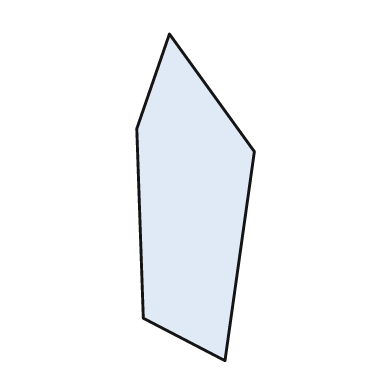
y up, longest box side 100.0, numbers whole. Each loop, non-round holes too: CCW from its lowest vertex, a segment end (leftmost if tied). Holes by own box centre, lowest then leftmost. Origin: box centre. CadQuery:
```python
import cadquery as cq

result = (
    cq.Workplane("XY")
    .moveTo(9.0, -50.0)
    .lineTo(18.0, 14.0)
    .lineTo(-8.0, 50.0)
    .lineTo(-18.0, 21.0)
    .lineTo(-16.0, -37.0)
    .close()
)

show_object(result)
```